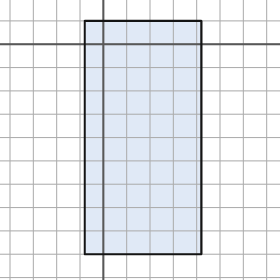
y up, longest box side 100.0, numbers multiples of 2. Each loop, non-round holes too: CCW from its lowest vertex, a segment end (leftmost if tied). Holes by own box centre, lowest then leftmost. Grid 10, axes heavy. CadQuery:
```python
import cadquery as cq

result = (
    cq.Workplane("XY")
    .moveTo(-8.0, -90.0)
    .lineTo(42.0, -90.0)
    .lineTo(42.0, 10.0)
    .lineTo(-8.0, 10.0)
    .close()
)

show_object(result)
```